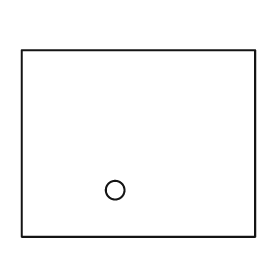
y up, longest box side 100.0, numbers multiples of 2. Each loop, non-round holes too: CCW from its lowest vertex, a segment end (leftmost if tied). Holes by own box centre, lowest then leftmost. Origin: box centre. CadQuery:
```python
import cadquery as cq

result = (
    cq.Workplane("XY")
    .moveTo(-50.0, -40.0)
    .lineTo(50.0, -40.0)
    .lineTo(50.0, 40.0)
    .lineTo(-50.0, 40.0)
    .close()
    .moveTo(-10.0, -20.0)
    .circle(4.0)
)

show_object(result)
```